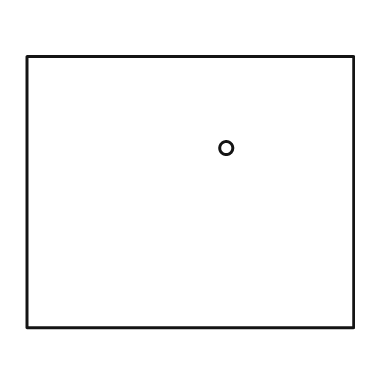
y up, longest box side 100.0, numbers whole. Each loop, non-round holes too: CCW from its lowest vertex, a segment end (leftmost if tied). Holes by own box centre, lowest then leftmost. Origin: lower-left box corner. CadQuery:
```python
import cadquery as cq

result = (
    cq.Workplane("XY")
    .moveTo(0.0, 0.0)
    .lineTo(100.0, 0.0)
    .lineTo(100.0, 83.0)
    .lineTo(0.0, 83.0)
    .close()
    .moveTo(61.0, 55.0)
    .circle(2.0)
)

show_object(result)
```